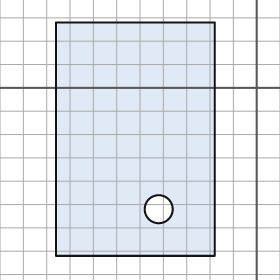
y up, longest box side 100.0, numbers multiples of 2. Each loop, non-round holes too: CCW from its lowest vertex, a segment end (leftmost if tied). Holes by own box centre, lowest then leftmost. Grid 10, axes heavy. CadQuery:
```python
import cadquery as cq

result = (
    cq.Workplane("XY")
    .moveTo(-86.0, -72.0)
    .lineTo(-18.0, -72.0)
    .lineTo(-18.0, 28.0)
    .lineTo(-86.0, 28.0)
    .close()
    .moveTo(-42.0, -52.0)
    .circle(6.0)
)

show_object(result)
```